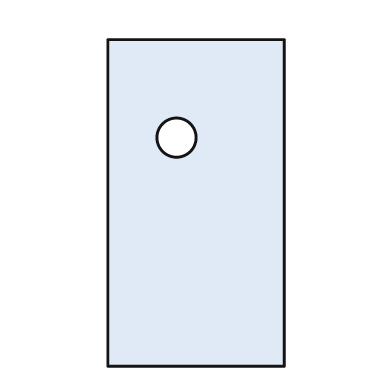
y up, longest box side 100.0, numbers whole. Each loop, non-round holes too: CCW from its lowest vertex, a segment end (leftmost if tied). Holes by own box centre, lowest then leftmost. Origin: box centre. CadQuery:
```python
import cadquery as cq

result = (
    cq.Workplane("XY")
    .moveTo(-27.0, -50.0)
    .lineTo(27.0, -50.0)
    .lineTo(27.0, 50.0)
    .lineTo(-27.0, 50.0)
    .close()
    .moveTo(-6.0, 20.0)
    .circle(6.0)
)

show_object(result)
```